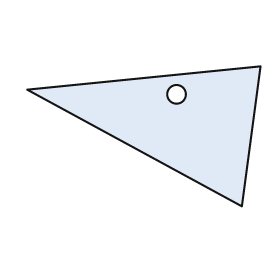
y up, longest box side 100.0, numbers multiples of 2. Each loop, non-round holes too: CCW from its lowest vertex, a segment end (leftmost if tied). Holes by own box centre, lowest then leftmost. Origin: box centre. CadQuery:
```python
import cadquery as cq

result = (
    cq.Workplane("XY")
    .moveTo(42.0, -30.0)
    .lineTo(50.0, 30.0)
    .lineTo(-50.0, 20.0)
    .close()
    .moveTo(14.0, 18.0)
    .circle(4.0)
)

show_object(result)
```